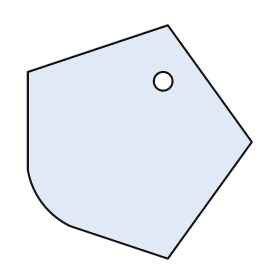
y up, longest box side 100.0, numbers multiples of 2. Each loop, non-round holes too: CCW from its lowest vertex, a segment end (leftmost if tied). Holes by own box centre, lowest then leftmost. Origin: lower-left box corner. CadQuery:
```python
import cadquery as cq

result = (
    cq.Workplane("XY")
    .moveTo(60.0, 0.0)
    .lineTo(96.0, 50.0)
    .lineTo(60.0, 100.0)
    .lineTo(0.0, 80.0)
    .lineTo(0.0, 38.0)
    .threePointArc((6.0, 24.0), (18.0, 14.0))
    .close()
    .moveTo(58.0, 76.0)
    .circle(4.0)
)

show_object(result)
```